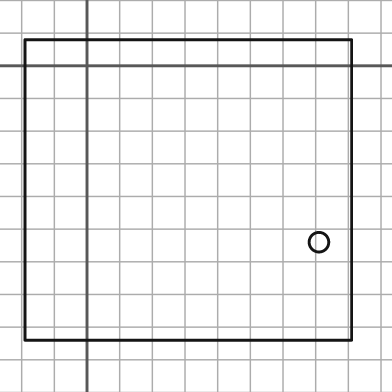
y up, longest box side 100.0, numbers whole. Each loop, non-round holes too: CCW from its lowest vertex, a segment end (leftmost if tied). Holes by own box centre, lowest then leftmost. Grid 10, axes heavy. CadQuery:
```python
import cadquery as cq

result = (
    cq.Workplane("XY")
    .moveTo(-19.0, -84.0)
    .lineTo(81.0, -84.0)
    .lineTo(81.0, 8.0)
    .lineTo(-19.0, 8.0)
    .close()
    .moveTo(71.0, -54.0)
    .circle(3.0)
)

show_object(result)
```